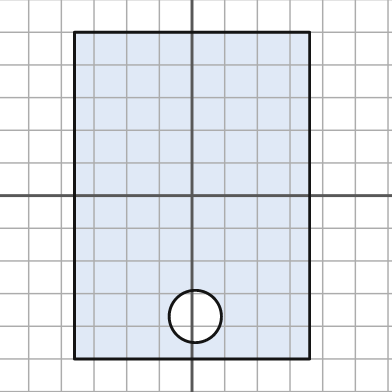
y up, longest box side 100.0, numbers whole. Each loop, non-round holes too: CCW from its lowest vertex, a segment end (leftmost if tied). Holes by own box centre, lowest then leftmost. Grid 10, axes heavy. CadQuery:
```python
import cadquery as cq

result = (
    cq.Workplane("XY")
    .moveTo(-36.0, -50.0)
    .lineTo(36.0, -50.0)
    .lineTo(36.0, 50.0)
    .lineTo(-36.0, 50.0)
    .close()
    .moveTo(1.0, -37.0)
    .circle(8.0)
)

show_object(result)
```